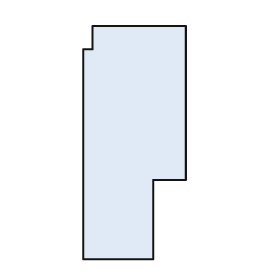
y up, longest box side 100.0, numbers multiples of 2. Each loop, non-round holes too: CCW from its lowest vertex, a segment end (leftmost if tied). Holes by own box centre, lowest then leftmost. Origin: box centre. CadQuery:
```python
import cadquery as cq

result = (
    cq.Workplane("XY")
    .moveTo(-22.0, -50.0)
    .lineTo(8.0, -50.0)
    .lineTo(8.0, -16.0)
    .lineTo(22.0, -16.0)
    .lineTo(22.0, 50.0)
    .lineTo(-18.0, 50.0)
    .lineTo(-18.0, 40.0)
    .lineTo(-22.0, 40.0)
    .close()
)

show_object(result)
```